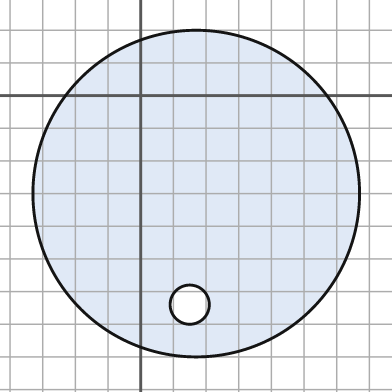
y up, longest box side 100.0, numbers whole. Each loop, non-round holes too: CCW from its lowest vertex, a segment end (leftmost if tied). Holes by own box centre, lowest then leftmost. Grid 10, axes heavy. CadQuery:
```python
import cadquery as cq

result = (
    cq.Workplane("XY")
    .moveTo(17.0, -30.0)
    .circle(50.0)
    .moveTo(15.0, -64.0)
    .circle(6.0)
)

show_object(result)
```